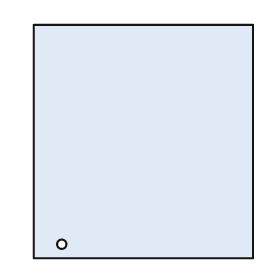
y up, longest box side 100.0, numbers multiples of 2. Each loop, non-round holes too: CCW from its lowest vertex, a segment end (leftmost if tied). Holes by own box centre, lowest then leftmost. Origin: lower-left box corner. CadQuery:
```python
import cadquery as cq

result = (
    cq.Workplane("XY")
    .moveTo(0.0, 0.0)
    .lineTo(94.0, 0.0)
    .lineTo(94.0, 100.0)
    .lineTo(0.0, 100.0)
    .close()
    .moveTo(12.0, 6.0)
    .circle(2.0)
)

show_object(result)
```